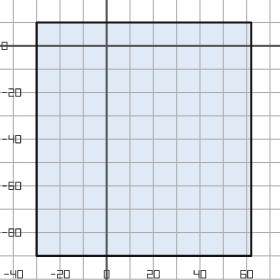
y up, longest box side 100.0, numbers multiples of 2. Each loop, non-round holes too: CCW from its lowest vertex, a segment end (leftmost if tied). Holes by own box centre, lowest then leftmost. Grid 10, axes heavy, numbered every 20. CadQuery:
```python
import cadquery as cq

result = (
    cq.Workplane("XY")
    .moveTo(-30.0, -90.0)
    .lineTo(62.0, -90.0)
    .lineTo(62.0, 10.0)
    .lineTo(-30.0, 10.0)
    .close()
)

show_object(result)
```